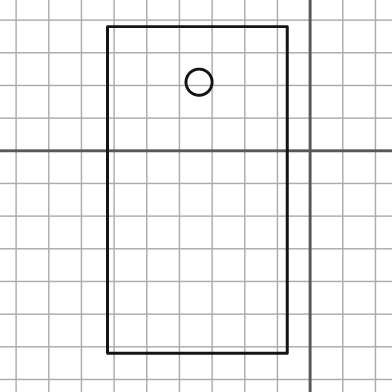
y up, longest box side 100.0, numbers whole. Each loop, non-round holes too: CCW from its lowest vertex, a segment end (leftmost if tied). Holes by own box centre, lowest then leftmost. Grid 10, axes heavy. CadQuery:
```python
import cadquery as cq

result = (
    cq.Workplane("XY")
    .moveTo(-62.0, -62.0)
    .lineTo(-7.0, -62.0)
    .lineTo(-7.0, 38.0)
    .lineTo(-62.0, 38.0)
    .close()
    .moveTo(-34.0, 21.0)
    .circle(4.0)
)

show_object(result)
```